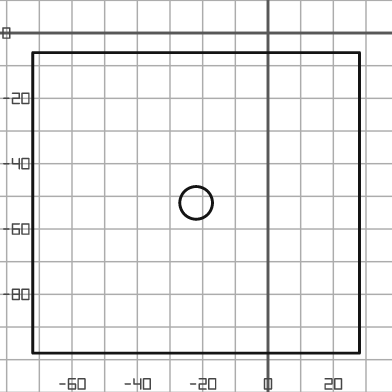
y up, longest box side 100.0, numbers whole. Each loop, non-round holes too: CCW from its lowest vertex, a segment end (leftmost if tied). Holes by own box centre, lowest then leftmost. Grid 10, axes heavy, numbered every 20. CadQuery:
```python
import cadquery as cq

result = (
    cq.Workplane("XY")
    .moveTo(-72.0, -98.0)
    .lineTo(28.0, -98.0)
    .lineTo(28.0, -6.0)
    .lineTo(-72.0, -6.0)
    .close()
    .moveTo(-22.0, -52.0)
    .circle(5.0)
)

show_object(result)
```